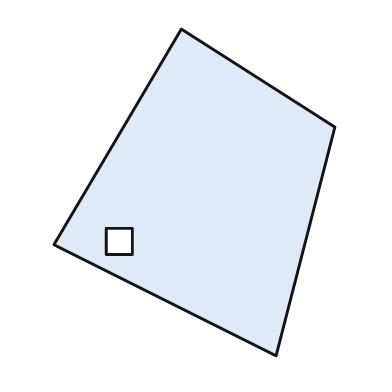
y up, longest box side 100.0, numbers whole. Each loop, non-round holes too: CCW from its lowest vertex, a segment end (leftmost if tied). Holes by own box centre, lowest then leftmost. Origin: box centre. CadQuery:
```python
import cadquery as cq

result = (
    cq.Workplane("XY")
    .moveTo(25.0, -50.0)
    .lineTo(43.0, 20.0)
    .lineTo(-4.0, 50.0)
    .lineTo(-43.0, -16.0)
    .close()
    .moveTo(-27.0, -19.0)
    .lineTo(-19.0, -19.0)
    .lineTo(-19.0, -11.0)
    .lineTo(-27.0, -11.0)
    .close()
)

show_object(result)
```